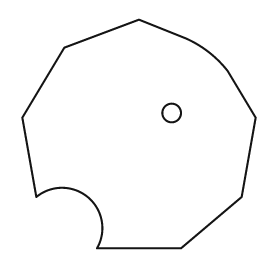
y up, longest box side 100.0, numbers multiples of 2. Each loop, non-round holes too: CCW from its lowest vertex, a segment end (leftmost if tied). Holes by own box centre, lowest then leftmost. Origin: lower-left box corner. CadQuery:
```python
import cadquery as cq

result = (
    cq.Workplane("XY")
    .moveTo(32.0, 0.0)
    .lineTo(68.0, 0.0)
    .lineTo(94.0, 22.0)
    .lineTo(100.0, 56.0)
    .lineTo(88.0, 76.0)
    .threePointArc((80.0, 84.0), (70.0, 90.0))
    .lineTo(50.0, 98.0)
    .lineTo(18.0, 86.0)
    .lineTo(0.0, 56.0)
    .lineTo(6.0, 22.0)
    .threePointArc((28.0, 22.0), (32.0, 0.0))
    .close()
    .moveTo(64.0, 58.0)
    .circle(4.0)
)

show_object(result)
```